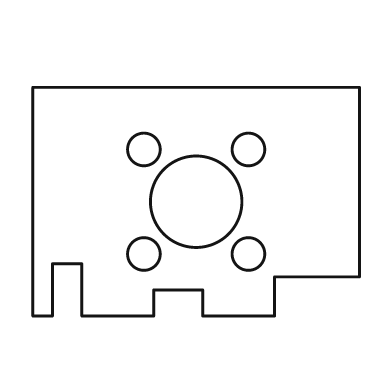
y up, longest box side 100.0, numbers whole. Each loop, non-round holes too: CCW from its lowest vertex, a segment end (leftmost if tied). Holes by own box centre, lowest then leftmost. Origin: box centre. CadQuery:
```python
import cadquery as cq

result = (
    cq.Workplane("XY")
    .moveTo(-50.0, -35.0)
    .lineTo(-44.0, -35.0)
    .lineTo(-44.0, -19.0)
    .lineTo(-35.0, -19.0)
    .lineTo(-35.0, -35.0)
    .lineTo(-13.0, -35.0)
    .lineTo(-13.0, -27.0)
    .lineTo(2.0, -27.0)
    .lineTo(2.0, -35.0)
    .lineTo(24.0, -35.0)
    .lineTo(24.0, -23.0)
    .lineTo(50.0, -23.0)
    .lineTo(50.0, 35.0)
    .lineTo(-50.0, 35.0)
    .close()
    .moveTo(-16.0, -16.0)
    .circle(5.0)
    .moveTo(16.0, -16.0)
    .circle(5.0)
    .moveTo(0.0, 0.0)
    .circle(14.0)
    .moveTo(-16.0, 16.0)
    .circle(5.0)
    .moveTo(16.0, 16.0)
    .circle(5.0)
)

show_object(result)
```